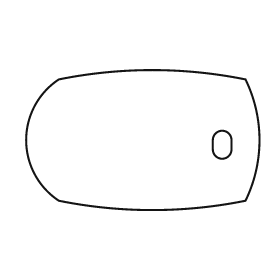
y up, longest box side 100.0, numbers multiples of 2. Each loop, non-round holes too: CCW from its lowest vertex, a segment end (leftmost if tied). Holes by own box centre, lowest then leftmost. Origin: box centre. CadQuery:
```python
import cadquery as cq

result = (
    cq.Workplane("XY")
    .moveTo(-36.0, -26.0)
    .threePointArc((4.0, -30.0), (44.0, -26.0))
    .threePointArc((50.0, 0.0), (44.0, 26.0))
    .threePointArc((4.0, 30.0), (-36.0, 26.0))
    .threePointArc((-50.0, 0.0), (-36.0, -26.0))
    .close()
    .moveTo(30.0, -4.0)
    .threePointArc((34.0, -8.0), (38.0, -4.0))
    .lineTo(38.0, 0.0)
    .threePointArc((34.0, 4.0), (30.0, 0.0))
    .close()
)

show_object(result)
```